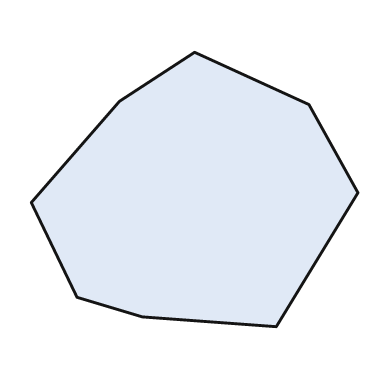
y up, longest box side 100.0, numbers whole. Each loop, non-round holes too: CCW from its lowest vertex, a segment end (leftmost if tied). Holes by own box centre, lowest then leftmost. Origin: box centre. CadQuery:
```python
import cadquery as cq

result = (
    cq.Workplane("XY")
    .moveTo(25.0, -42.0)
    .lineTo(50.0, -1.0)
    .lineTo(35.0, 26.0)
    .lineTo(0.0, 42.0)
    .lineTo(-23.0, 27.0)
    .lineTo(-50.0, -4.0)
    .lineTo(-36.0, -33.0)
    .lineTo(-16.0, -39.0)
    .close()
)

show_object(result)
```